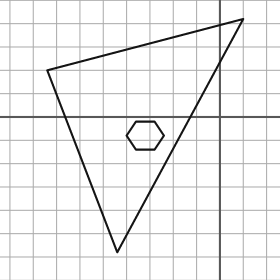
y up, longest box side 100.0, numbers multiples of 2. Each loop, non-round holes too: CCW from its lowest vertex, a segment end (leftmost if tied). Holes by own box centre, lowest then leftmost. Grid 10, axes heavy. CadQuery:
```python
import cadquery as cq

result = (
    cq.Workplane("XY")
    .moveTo(-44.0, -58.0)
    .lineTo(10.0, 42.0)
    .lineTo(-74.0, 20.0)
    .close()
    .moveTo(-36.0, -14.0)
    .lineTo(-28.0, -14.0)
    .lineTo(-24.0, -8.0)
    .lineTo(-28.0, -2.0)
    .lineTo(-36.0, -2.0)
    .lineTo(-40.0, -8.0)
    .close()
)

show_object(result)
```